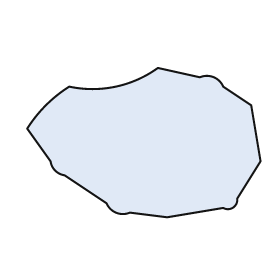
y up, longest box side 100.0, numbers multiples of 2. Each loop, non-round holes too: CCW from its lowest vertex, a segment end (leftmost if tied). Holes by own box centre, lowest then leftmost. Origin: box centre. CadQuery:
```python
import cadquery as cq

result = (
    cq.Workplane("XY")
    .moveTo(10.0, -32.0)
    .lineTo(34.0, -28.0)
    .threePointArc((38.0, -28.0), (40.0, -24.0))
    .lineTo(50.0, -8.0)
    .lineTo(46.0, 16.0)
    .lineTo(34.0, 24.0)
    .threePointArc((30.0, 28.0), (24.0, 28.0))
    .lineTo(6.0, 32.0)
    .threePointArc((-12.0, 24.0), (-32.0, 24.0))
    .threePointArc((-42.0, 16.0), (-50.0, 6.0))
    .lineTo(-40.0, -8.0)
    .threePointArc((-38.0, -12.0), (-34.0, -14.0))
    .lineTo(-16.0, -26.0)
    .threePointArc((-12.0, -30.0), (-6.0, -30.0))
    .close()
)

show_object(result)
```